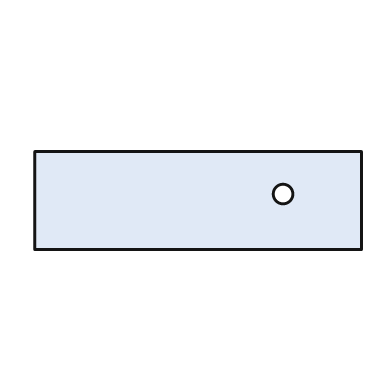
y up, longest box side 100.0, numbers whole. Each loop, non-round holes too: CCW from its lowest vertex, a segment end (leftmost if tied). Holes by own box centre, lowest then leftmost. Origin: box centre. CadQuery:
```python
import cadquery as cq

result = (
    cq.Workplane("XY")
    .moveTo(-50.0, -15.0)
    .lineTo(50.0, -15.0)
    .lineTo(50.0, 15.0)
    .lineTo(-50.0, 15.0)
    .close()
    .moveTo(26.0, 2.0)
    .circle(3.0)
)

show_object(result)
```